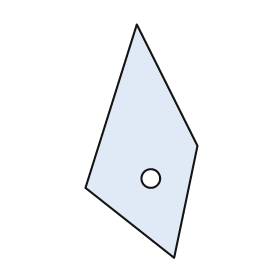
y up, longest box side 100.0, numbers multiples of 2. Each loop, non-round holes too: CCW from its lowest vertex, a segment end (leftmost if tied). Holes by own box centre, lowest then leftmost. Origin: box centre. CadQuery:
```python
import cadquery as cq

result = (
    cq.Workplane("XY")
    .moveTo(14.0, -50.0)
    .lineTo(24.0, -2.0)
    .lineTo(-2.0, 50.0)
    .lineTo(-24.0, -20.0)
    .close()
    .moveTo(4.0, -16.0)
    .circle(4.0)
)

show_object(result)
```